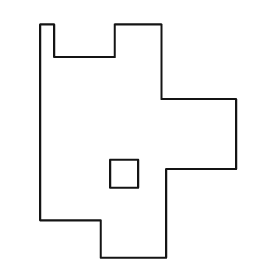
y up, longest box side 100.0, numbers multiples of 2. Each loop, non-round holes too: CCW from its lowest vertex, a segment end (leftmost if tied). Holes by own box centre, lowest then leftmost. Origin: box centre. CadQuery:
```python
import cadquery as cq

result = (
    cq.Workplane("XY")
    .moveTo(-16.0, -50.0)
    .lineTo(12.0, -50.0)
    .lineTo(12.0, -12.0)
    .lineTo(42.0, -12.0)
    .lineTo(42.0, 18.0)
    .lineTo(10.0, 18.0)
    .lineTo(10.0, 50.0)
    .lineTo(-10.0, 50.0)
    .lineTo(-10.0, 36.0)
    .lineTo(-36.0, 36.0)
    .lineTo(-36.0, 50.0)
    .lineTo(-42.0, 50.0)
    .lineTo(-42.0, -34.0)
    .lineTo(-16.0, -34.0)
    .close()
    .moveTo(-12.0, -20.0)
    .lineTo(0.0, -20.0)
    .lineTo(0.0, -8.0)
    .lineTo(-12.0, -8.0)
    .close()
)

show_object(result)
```